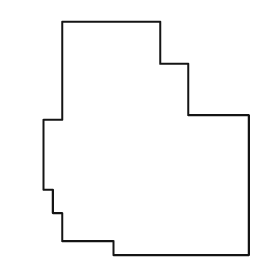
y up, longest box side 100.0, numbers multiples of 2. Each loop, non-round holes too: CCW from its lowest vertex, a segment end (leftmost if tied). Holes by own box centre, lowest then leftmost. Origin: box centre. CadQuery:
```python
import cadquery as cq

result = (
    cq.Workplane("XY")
    .moveTo(-14.0, -50.0)
    .lineTo(44.0, -50.0)
    .lineTo(44.0, 10.0)
    .lineTo(18.0, 10.0)
    .lineTo(18.0, 32.0)
    .lineTo(6.0, 32.0)
    .lineTo(6.0, 50.0)
    .lineTo(-36.0, 50.0)
    .lineTo(-36.0, 8.0)
    .lineTo(-44.0, 8.0)
    .lineTo(-44.0, -22.0)
    .lineTo(-40.0, -22.0)
    .lineTo(-40.0, -32.0)
    .lineTo(-36.0, -32.0)
    .lineTo(-36.0, -44.0)
    .lineTo(-14.0, -44.0)
    .close()
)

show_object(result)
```